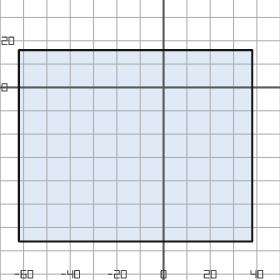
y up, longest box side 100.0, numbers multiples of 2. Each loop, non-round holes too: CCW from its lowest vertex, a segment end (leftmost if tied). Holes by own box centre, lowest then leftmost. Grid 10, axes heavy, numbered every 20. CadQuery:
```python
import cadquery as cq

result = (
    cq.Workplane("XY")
    .moveTo(-62.0, -66.0)
    .lineTo(38.0, -66.0)
    .lineTo(38.0, 16.0)
    .lineTo(-62.0, 16.0)
    .close()
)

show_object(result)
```